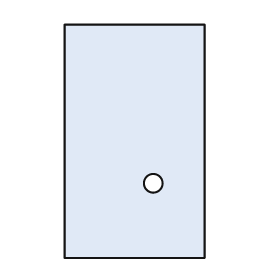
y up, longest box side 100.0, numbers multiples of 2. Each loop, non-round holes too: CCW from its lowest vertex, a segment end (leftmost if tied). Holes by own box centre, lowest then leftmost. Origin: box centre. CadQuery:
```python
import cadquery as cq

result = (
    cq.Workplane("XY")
    .moveTo(-30.0, -50.0)
    .lineTo(30.0, -50.0)
    .lineTo(30.0, 50.0)
    .lineTo(-30.0, 50.0)
    .close()
    .moveTo(8.0, -18.0)
    .circle(4.0)
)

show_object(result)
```